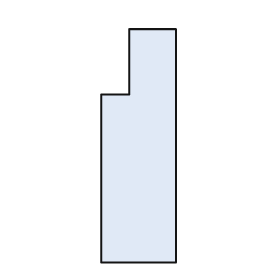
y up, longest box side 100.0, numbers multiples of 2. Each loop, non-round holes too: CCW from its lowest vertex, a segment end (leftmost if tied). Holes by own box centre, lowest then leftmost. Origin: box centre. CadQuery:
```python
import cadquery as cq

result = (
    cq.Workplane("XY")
    .moveTo(-16.0, -50.0)
    .lineTo(16.0, -50.0)
    .lineTo(16.0, 50.0)
    .lineTo(-4.0, 50.0)
    .lineTo(-4.0, 22.0)
    .lineTo(-16.0, 22.0)
    .close()
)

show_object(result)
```